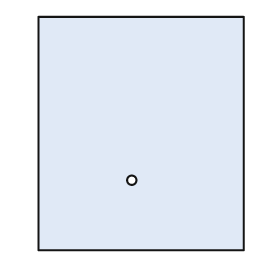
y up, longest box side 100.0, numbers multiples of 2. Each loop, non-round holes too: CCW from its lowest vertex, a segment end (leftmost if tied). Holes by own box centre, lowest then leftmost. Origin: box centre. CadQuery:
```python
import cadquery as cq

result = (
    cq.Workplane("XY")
    .moveTo(-44.0, -50.0)
    .lineTo(44.0, -50.0)
    .lineTo(44.0, 50.0)
    .lineTo(-44.0, 50.0)
    .close()
    .moveTo(-4.0, -20.0)
    .circle(2.0)
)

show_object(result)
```